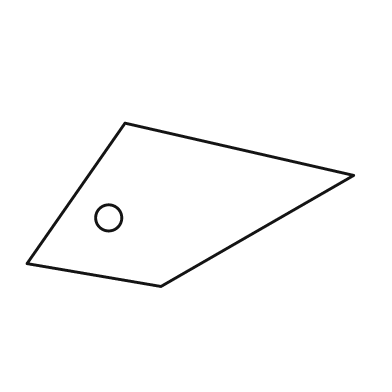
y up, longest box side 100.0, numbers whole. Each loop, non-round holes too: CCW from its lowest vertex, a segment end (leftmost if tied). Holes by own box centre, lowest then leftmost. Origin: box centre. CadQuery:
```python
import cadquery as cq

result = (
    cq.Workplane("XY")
    .moveTo(-9.0, -25.0)
    .lineTo(50.0, 9.0)
    .lineTo(-20.0, 25.0)
    .lineTo(-50.0, -18.0)
    .close()
    .moveTo(-25.0, -4.0)
    .circle(4.0)
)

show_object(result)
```